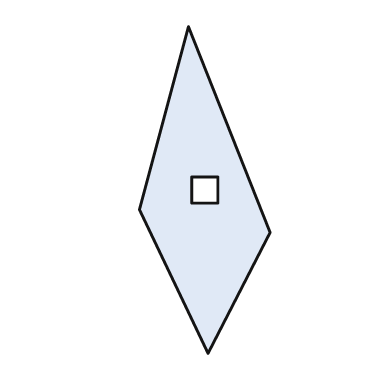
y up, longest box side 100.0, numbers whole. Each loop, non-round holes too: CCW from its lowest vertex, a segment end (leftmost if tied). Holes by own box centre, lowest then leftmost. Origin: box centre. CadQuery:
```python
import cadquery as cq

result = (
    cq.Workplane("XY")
    .moveTo(1.0, -50.0)
    .lineTo(20.0, -13.0)
    .lineTo(-5.0, 50.0)
    .lineTo(-20.0, -6.0)
    .close()
    .moveTo(-4.0, -4.0)
    .lineTo(4.0, -4.0)
    .lineTo(4.0, 4.0)
    .lineTo(-4.0, 4.0)
    .close()
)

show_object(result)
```